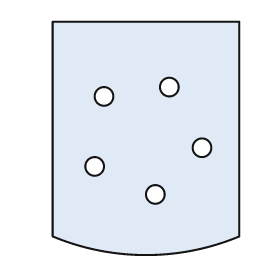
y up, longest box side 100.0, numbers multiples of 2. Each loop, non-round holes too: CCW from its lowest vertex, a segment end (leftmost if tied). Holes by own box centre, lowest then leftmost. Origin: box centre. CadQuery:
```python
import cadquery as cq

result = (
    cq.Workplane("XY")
    .moveTo(-40.0, -42.0)
    .threePointArc((0.0, -50.0), (40.0, -42.0))
    .lineTo(40.0, 50.0)
    .lineTo(-40.0, 50.0)
    .close()
    .moveTo(4.0, -24.0)
    .circle(4.0)
    .moveTo(-22.0, -12.0)
    .circle(4.0)
    .moveTo(24.0, -4.0)
    .circle(4.0)
    .moveTo(-18.0, 18.0)
    .circle(4.0)
    .moveTo(10.0, 22.0)
    .circle(4.0)
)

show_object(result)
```